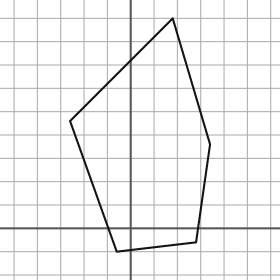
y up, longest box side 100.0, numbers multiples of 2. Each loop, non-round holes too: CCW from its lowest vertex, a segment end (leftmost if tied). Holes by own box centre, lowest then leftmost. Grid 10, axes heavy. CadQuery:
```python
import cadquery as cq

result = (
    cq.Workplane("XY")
    .moveTo(-6.0, -10.0)
    .lineTo(28.0, -6.0)
    .lineTo(34.0, 36.0)
    .lineTo(18.0, 90.0)
    .lineTo(-26.0, 46.0)
    .close()
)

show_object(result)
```